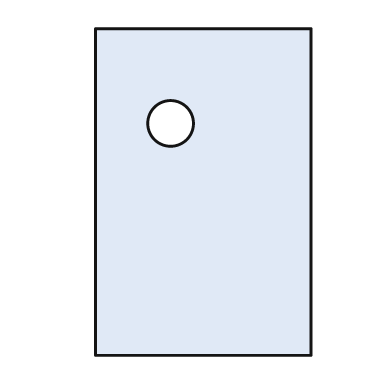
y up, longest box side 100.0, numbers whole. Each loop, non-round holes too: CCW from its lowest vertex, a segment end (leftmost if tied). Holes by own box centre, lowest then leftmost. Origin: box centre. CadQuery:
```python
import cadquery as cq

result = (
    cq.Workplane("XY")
    .moveTo(-33.0, -50.0)
    .lineTo(33.0, -50.0)
    .lineTo(33.0, 50.0)
    .lineTo(-33.0, 50.0)
    .close()
    .moveTo(-10.0, 21.0)
    .circle(7.0)
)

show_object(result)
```